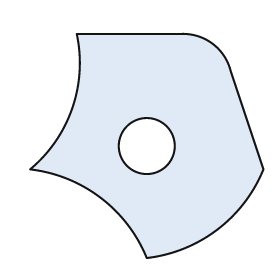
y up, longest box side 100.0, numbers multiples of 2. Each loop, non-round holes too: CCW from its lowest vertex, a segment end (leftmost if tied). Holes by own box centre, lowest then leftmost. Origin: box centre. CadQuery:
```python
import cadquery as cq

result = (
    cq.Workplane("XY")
    .moveTo(0.0, -48.0)
    .threePointArc((30.0, -36.0), (50.0, -10.0))
    .lineTo(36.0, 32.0)
    .threePointArc((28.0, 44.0), (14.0, 48.0))
    .lineTo(-30.0, 48.0)
    .threePointArc((-32.0, 16.0), (-50.0, -10.0))
    .threePointArc((-20.0, -22.0), (0.0, -48.0))
    .close()
    .moveTo(0.0, 0.0)
    .circle(12.0)
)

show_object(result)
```